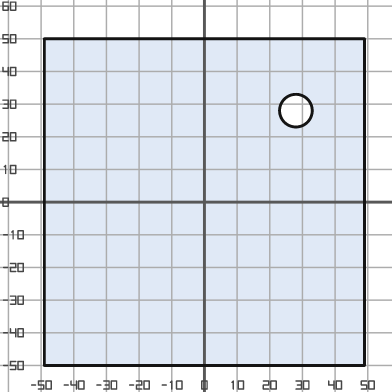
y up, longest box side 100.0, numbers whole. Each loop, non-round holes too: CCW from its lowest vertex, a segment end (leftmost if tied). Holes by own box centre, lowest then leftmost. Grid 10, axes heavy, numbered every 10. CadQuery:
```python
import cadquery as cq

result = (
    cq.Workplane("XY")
    .moveTo(-49.0, -50.0)
    .lineTo(49.0, -50.0)
    .lineTo(49.0, 50.0)
    .lineTo(-49.0, 50.0)
    .close()
    .moveTo(28.0, 28.0)
    .circle(5.0)
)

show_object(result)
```